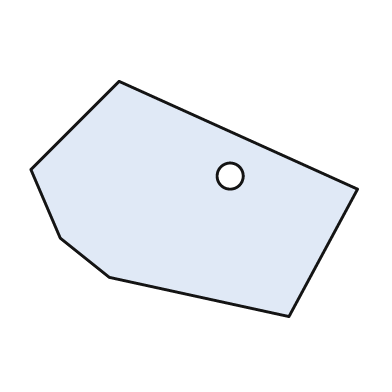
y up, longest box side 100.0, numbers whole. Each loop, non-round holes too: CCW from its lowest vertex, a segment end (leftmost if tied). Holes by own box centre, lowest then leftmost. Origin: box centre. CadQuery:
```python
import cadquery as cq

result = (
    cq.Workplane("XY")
    .moveTo(29.0, -36.0)
    .lineTo(50.0, 3.0)
    .lineTo(-23.0, 36.0)
    .lineTo(-50.0, 9.0)
    .lineTo(-41.0, -12.0)
    .lineTo(-26.0, -24.0)
    .close()
    .moveTo(11.0, 7.0)
    .circle(4.0)
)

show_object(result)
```